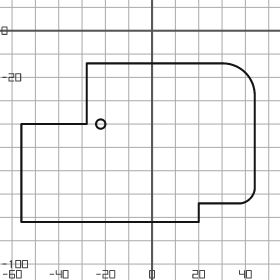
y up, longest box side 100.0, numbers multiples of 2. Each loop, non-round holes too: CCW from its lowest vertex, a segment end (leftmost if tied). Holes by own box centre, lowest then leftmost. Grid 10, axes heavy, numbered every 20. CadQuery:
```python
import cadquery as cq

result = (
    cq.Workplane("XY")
    .moveTo(-56.0, -82.0)
    .lineTo(20.0, -82.0)
    .lineTo(20.0, -74.0)
    .lineTo(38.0, -74.0)
    .threePointArc((42.0, -72.0), (44.0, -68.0))
    .lineTo(44.0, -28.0)
    .threePointArc((40.0, -18.0), (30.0, -14.0))
    .lineTo(-28.0, -14.0)
    .lineTo(-28.0, -40.0)
    .lineTo(-56.0, -40.0)
    .close()
    .moveTo(-22.0, -40.0)
    .circle(2.0)
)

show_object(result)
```